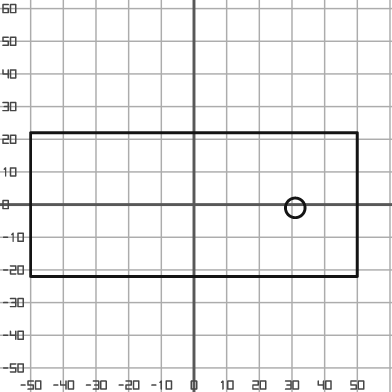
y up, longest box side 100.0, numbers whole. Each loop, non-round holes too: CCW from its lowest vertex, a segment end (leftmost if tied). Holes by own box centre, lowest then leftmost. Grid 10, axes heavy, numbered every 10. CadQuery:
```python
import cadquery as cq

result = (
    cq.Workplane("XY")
    .moveTo(-50.0, -22.0)
    .lineTo(50.0, -22.0)
    .lineTo(50.0, 22.0)
    .lineTo(-50.0, 22.0)
    .close()
    .moveTo(31.0, -1.0)
    .circle(3.0)
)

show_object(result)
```